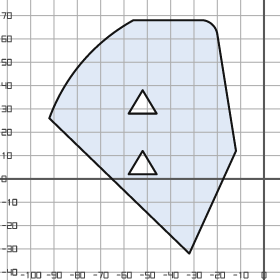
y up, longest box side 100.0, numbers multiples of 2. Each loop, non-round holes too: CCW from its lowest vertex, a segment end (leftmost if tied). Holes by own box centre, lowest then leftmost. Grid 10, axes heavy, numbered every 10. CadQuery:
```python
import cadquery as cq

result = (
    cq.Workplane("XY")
    .moveTo(-32.0, -32.0)
    .lineTo(-12.0, 12.0)
    .lineTo(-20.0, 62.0)
    .threePointArc((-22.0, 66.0), (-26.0, 68.0))
    .lineTo(-56.0, 68.0)
    .threePointArc((-78.0, 50.0), (-92.0, 26.0))
    .close()
    .moveTo(-58.0, 2.0)
    .lineTo(-46.0, 2.0)
    .lineTo(-52.0, 12.0)
    .close()
    .moveTo(-58.0, 28.0)
    .lineTo(-46.0, 28.0)
    .lineTo(-52.0, 38.0)
    .close()
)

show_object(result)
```